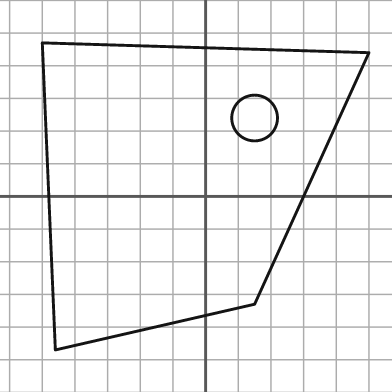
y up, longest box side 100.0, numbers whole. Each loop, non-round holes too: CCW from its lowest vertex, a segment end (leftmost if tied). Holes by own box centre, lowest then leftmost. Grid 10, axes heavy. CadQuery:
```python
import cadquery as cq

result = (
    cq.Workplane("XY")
    .moveTo(-46.0, -47.0)
    .lineTo(15.0, -33.0)
    .lineTo(50.0, 44.0)
    .lineTo(-50.0, 47.0)
    .close()
    .moveTo(15.0, 24.0)
    .circle(7.0)
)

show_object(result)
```